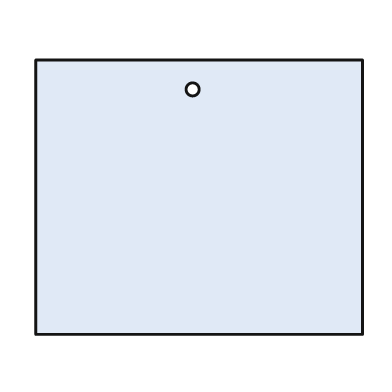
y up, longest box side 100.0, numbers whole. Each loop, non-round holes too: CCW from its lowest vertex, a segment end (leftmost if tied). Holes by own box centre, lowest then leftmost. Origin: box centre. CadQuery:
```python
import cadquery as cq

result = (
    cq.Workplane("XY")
    .moveTo(-50.0, -42.0)
    .lineTo(50.0, -42.0)
    .lineTo(50.0, 42.0)
    .lineTo(-50.0, 42.0)
    .close()
    .moveTo(-2.0, 33.0)
    .circle(2.0)
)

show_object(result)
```